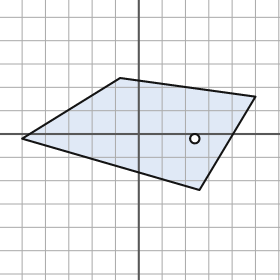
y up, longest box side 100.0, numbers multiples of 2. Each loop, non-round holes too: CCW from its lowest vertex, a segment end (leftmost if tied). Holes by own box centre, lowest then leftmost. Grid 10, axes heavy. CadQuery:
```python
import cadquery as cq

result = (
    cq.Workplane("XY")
    .moveTo(26.0, -24.0)
    .lineTo(50.0, 16.0)
    .lineTo(-8.0, 24.0)
    .lineTo(-50.0, -2.0)
    .close()
    .moveTo(24.0, -2.0)
    .circle(2.0)
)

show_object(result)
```